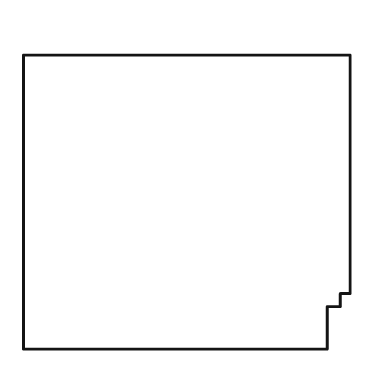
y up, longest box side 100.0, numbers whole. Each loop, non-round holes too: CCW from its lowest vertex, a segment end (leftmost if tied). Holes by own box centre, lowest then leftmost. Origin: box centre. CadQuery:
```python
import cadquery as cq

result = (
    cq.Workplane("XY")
    .moveTo(-50.0, -45.0)
    .lineTo(43.0, -45.0)
    .lineTo(43.0, -32.0)
    .lineTo(47.0, -32.0)
    .lineTo(47.0, -28.0)
    .lineTo(50.0, -28.0)
    .lineTo(50.0, 45.0)
    .lineTo(-50.0, 45.0)
    .close()
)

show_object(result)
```